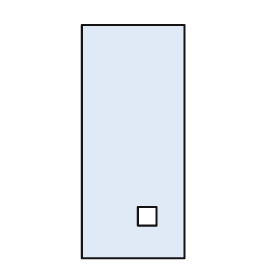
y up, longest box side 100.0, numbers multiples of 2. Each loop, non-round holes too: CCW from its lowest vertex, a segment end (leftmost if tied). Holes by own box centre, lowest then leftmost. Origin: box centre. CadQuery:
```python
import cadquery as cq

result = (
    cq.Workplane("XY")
    .moveTo(-22.0, -50.0)
    .lineTo(22.0, -50.0)
    .lineTo(22.0, 50.0)
    .lineTo(-22.0, 50.0)
    .close()
    .moveTo(2.0, -36.0)
    .lineTo(10.0, -36.0)
    .lineTo(10.0, -28.0)
    .lineTo(2.0, -28.0)
    .close()
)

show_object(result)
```